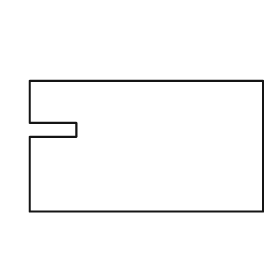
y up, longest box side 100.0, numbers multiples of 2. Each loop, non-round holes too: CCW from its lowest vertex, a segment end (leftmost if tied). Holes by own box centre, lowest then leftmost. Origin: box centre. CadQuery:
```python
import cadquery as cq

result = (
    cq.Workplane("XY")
    .moveTo(-50.0, -28.0)
    .lineTo(50.0, -28.0)
    .lineTo(50.0, 28.0)
    .lineTo(-50.0, 28.0)
    .lineTo(-50.0, 10.0)
    .lineTo(-30.0, 10.0)
    .lineTo(-30.0, 4.0)
    .lineTo(-50.0, 4.0)
    .close()
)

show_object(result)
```